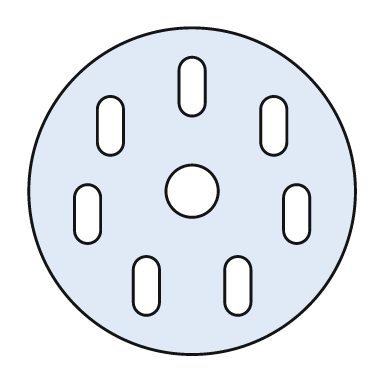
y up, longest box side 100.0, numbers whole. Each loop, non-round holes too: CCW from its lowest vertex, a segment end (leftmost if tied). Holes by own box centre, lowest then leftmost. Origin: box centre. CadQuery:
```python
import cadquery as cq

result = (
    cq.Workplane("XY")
    .moveTo(0.0, 0.0)
    .circle(50.0)
    .moveTo(-18.0, -34.0)
    .threePointArc((-14.0, -38.0), (-10.0, -34.0))
    .lineTo(-10.0, -24.0)
    .threePointArc((-14.0, -20.0), (-18.0, -24.0))
    .close()
    .moveTo(10.0, -34.0)
    .threePointArc((14.0, -38.0), (18.0, -34.0))
    .lineTo(18.0, -24.0)
    .threePointArc((14.0, -20.0), (10.0, -24.0))
    .close()
    .moveTo(-36.0, -12.0)
    .threePointArc((-32.0, -16.0), (-28.0, -12.0))
    .lineTo(-28.0, -2.0)
    .threePointArc((-32.0, 2.0), (-36.0, -2.0))
    .close()
    .moveTo(28.0, -12.0)
    .threePointArc((32.0, -16.0), (36.0, -12.0))
    .lineTo(36.0, -2.0)
    .threePointArc((32.0, 2.0), (28.0, -2.0))
    .close()
    .moveTo(0.0, 0.0)
    .circle(8.0)
    .moveTo(-29.0, 15.0)
    .threePointArc((-25.0, 11.0), (-21.0, 15.0))
    .lineTo(-21.0, 25.0)
    .threePointArc((-25.0, 29.0), (-29.0, 25.0))
    .close()
    .moveTo(21.0, 15.0)
    .threePointArc((25.0, 11.0), (29.0, 15.0))
    .lineTo(29.0, 25.0)
    .threePointArc((25.0, 29.0), (21.0, 25.0))
    .close()
    .moveTo(-4.0, 27.0)
    .threePointArc((0.0, 23.0), (4.0, 27.0))
    .lineTo(4.0, 37.0)
    .threePointArc((0.0, 41.0), (-4.0, 37.0))
    .close()
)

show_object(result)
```